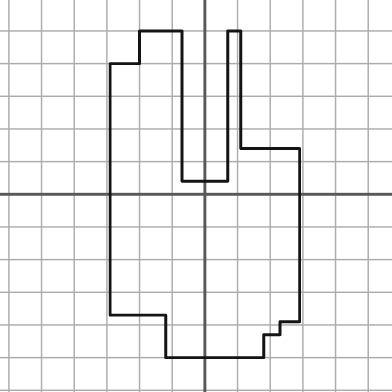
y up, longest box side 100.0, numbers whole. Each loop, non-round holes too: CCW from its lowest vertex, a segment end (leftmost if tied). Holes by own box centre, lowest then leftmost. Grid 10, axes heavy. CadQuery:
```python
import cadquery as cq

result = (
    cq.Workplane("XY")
    .moveTo(-12.0, -50.0)
    .lineTo(18.0, -50.0)
    .lineTo(18.0, -43.0)
    .lineTo(23.0, -43.0)
    .lineTo(23.0, -39.0)
    .lineTo(29.0, -39.0)
    .lineTo(29.0, 14.0)
    .lineTo(11.0, 14.0)
    .lineTo(11.0, 50.0)
    .lineTo(7.0, 50.0)
    .lineTo(7.0, 4.0)
    .lineTo(-7.0, 4.0)
    .lineTo(-7.0, 50.0)
    .lineTo(-20.0, 50.0)
    .lineTo(-20.0, 40.0)
    .lineTo(-29.0, 40.0)
    .lineTo(-29.0, -37.0)
    .lineTo(-12.0, -37.0)
    .close()
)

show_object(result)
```